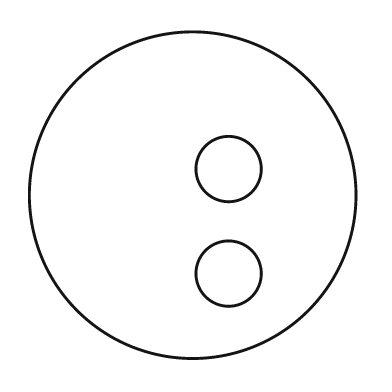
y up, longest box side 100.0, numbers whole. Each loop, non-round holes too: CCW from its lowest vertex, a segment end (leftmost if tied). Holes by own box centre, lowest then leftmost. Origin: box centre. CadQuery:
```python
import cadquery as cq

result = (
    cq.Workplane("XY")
    .moveTo(0.0, 0.0)
    .circle(50.0)
    .moveTo(11.0, -24.0)
    .circle(10.0)
    .moveTo(11.0, 8.0)
    .circle(10.0)
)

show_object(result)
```